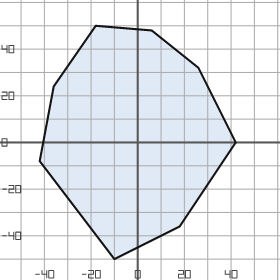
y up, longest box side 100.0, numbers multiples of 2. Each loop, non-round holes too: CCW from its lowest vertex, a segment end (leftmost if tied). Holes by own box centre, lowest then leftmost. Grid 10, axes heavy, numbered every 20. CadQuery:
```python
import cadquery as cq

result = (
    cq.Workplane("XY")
    .moveTo(-10.0, -50.0)
    .lineTo(18.0, -36.0)
    .lineTo(42.0, 0.0)
    .lineTo(26.0, 32.0)
    .lineTo(6.0, 48.0)
    .lineTo(-18.0, 50.0)
    .lineTo(-36.0, 24.0)
    .lineTo(-42.0, -8.0)
    .close()
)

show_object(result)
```